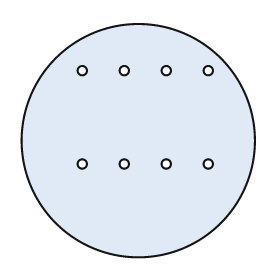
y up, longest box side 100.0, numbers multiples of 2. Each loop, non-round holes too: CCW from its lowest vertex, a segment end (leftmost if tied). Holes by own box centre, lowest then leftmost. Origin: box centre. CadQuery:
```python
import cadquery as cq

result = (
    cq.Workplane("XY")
    .moveTo(0.0, 0.0)
    .circle(50.0)
    .moveTo(-24.0, -10.0)
    .circle(2.0)
    .moveTo(-6.0, -10.0)
    .circle(2.0)
    .moveTo(12.0, -10.0)
    .circle(2.0)
    .moveTo(30.0, -10.0)
    .circle(2.0)
    .moveTo(-24.0, 30.0)
    .circle(2.0)
    .moveTo(-6.0, 30.0)
    .circle(2.0)
    .moveTo(12.0, 30.0)
    .circle(2.0)
    .moveTo(30.0, 30.0)
    .circle(2.0)
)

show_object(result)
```